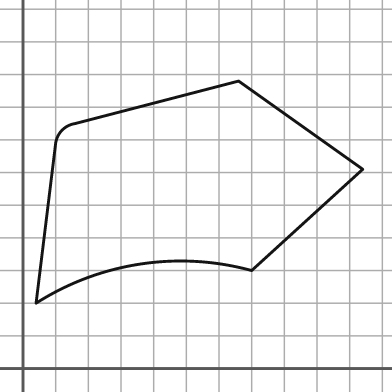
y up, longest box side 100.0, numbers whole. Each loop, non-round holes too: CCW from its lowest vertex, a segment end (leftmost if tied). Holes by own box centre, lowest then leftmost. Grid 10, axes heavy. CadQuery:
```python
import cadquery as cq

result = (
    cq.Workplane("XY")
    .moveTo(4.0, 20.0)
    .threePointArc((36.0, 32.0), (70.0, 30.0))
    .lineTo(104.0, 61.0)
    .lineTo(66.0, 88.0)
    .lineTo(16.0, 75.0)
    .threePointArc((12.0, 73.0), (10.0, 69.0))
    .close()
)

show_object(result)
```